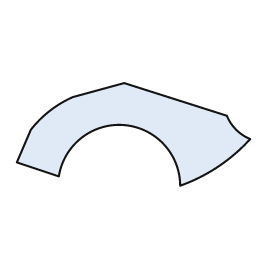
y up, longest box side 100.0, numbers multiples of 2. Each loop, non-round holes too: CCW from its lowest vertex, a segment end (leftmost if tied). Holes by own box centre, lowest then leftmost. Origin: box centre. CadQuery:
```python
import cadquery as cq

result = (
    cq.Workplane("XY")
    .moveTo(20.0, -22.0)
    .threePointArc((36.0, -14.0), (50.0, -2.0))
    .threePointArc((44.0, 2.0), (40.0, 8.0))
    .lineTo(-4.0, 22.0)
    .lineTo(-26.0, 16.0)
    .threePointArc((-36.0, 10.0), (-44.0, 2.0))
    .lineTo(-50.0, -12.0)
    .lineTo(-32.0, -18.0)
    .threePointArc((-4.0, 4.0), (20.0, -22.0))
    .close()
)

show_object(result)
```